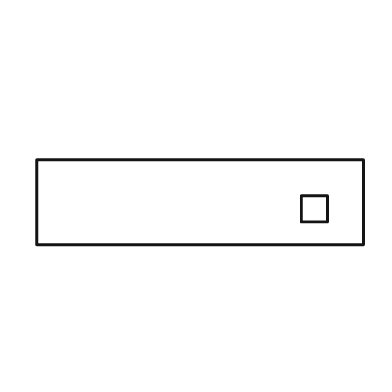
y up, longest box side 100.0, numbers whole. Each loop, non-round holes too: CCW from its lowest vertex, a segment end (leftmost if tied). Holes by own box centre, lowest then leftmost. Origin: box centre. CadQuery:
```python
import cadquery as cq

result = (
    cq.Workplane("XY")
    .moveTo(-50.0, -13.0)
    .lineTo(50.0, -13.0)
    .lineTo(50.0, 13.0)
    .lineTo(-50.0, 13.0)
    .close()
    .moveTo(31.0, -6.0)
    .lineTo(39.0, -6.0)
    .lineTo(39.0, 2.0)
    .lineTo(31.0, 2.0)
    .close()
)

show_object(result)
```